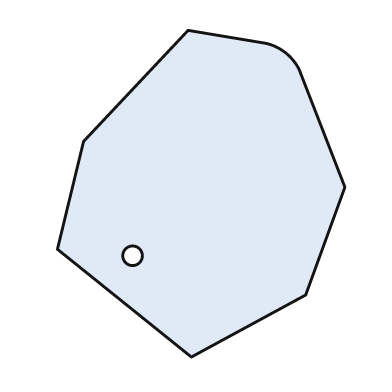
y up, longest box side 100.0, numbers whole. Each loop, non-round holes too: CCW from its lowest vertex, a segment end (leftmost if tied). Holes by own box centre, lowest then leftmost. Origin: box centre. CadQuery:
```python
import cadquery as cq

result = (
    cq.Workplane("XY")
    .moveTo(-3.0, -50.0)
    .lineTo(32.0, -31.0)
    .lineTo(44.0, 2.0)
    .lineTo(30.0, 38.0)
    .threePointArc((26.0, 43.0), (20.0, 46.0))
    .lineTo(-4.0, 50.0)
    .lineTo(-36.0, 16.0)
    .lineTo(-44.0, -17.0)
    .close()
    .moveTo(-21.0, -19.0)
    .circle(3.0)
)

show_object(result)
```